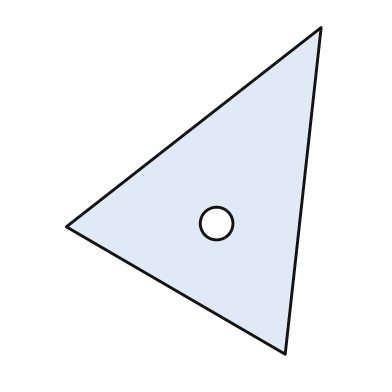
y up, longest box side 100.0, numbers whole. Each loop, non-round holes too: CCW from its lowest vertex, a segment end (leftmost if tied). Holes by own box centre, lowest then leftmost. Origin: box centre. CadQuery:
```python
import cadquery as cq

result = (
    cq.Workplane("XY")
    .moveTo(28.0, -50.0)
    .lineTo(39.0, 50.0)
    .lineTo(-39.0, -11.0)
    .close()
    .moveTo(7.0, -10.0)
    .circle(5.0)
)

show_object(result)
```